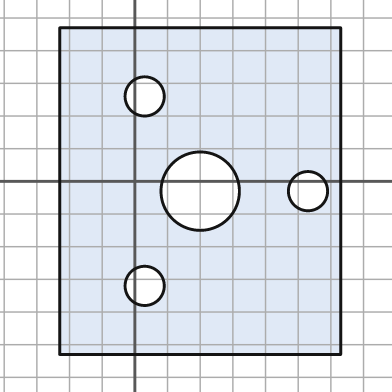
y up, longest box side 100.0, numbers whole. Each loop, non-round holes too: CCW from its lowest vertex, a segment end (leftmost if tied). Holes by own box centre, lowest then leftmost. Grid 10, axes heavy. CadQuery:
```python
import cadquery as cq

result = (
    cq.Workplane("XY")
    .moveTo(-23.0, -53.0)
    .lineTo(63.0, -53.0)
    .lineTo(63.0, 47.0)
    .lineTo(-23.0, 47.0)
    .close()
    .moveTo(3.0, -32.0)
    .circle(6.0)
    .moveTo(20.0, -3.0)
    .circle(12.0)
    .moveTo(53.0, -3.0)
    .circle(6.0)
    .moveTo(3.0, 26.0)
    .circle(6.0)
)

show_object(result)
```